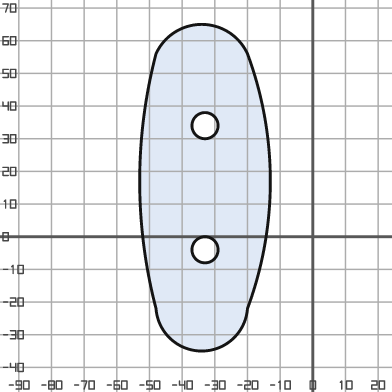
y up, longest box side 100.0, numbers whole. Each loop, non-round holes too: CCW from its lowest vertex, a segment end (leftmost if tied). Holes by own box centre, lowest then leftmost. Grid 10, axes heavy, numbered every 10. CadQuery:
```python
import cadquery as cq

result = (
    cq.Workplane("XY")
    .moveTo(-48.0, -22.0)
    .threePointArc((-34.0, -35.0), (-20.0, -22.0))
    .threePointArc((-13.0, 17.0), (-20.0, 56.0))
    .threePointArc((-34.0, 65.0), (-48.0, 56.0))
    .threePointArc((-53.0, 17.0), (-48.0, -22.0))
    .close()
    .moveTo(-33.0, -4.0)
    .circle(4.0)
    .moveTo(-33.0, 34.0)
    .circle(4.0)
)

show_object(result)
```